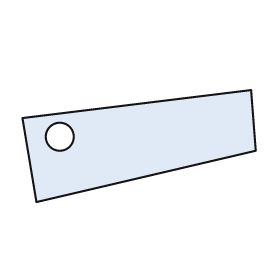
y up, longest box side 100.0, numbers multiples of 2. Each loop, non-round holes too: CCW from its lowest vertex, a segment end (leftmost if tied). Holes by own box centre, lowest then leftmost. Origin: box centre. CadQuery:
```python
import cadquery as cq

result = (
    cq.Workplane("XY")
    .moveTo(-44.0, -24.0)
    .lineTo(50.0, -2.0)
    .lineTo(48.0, 24.0)
    .lineTo(-50.0, 12.0)
    .close()
    .moveTo(-34.0, 4.0)
    .circle(6.0)
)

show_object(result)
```